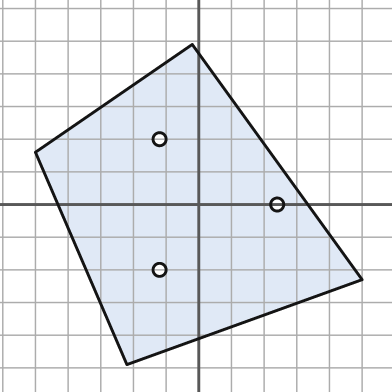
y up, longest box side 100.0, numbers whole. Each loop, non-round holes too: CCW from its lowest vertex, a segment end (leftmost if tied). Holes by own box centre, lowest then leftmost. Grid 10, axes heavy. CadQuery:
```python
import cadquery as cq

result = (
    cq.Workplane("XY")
    .moveTo(-22.0, -49.0)
    .lineTo(50.0, -23.0)
    .lineTo(-2.0, 49.0)
    .lineTo(-50.0, 16.0)
    .close()
    .moveTo(-12.0, -20.0)
    .circle(2.0)
    .moveTo(24.0, 0.0)
    .circle(2.0)
    .moveTo(-12.0, 20.0)
    .circle(2.0)
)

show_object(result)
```